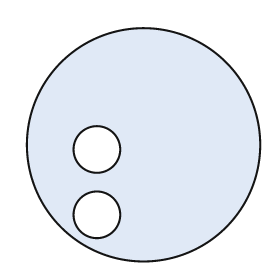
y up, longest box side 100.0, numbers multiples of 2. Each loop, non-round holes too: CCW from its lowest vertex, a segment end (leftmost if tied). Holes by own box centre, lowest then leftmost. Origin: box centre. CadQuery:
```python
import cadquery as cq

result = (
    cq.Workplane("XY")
    .moveTo(0.0, 0.0)
    .circle(50.0)
    .moveTo(-20.0, -30.0)
    .circle(10.0)
    .moveTo(-20.0, -2.0)
    .circle(10.0)
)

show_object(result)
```